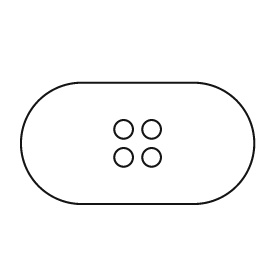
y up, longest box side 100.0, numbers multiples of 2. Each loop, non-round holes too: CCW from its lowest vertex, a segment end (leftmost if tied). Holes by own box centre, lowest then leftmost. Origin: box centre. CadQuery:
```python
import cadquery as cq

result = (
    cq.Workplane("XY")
    .moveTo(-24.0, -26.0)
    .lineTo(24.0, -26.0)
    .threePointArc((50.0, 0.0), (24.0, 26.0))
    .lineTo(-24.0, 26.0)
    .threePointArc((-50.0, 0.0), (-24.0, -26.0))
    .close()
    .moveTo(-6.0, -6.0)
    .circle(4.0)
    .moveTo(6.0, -6.0)
    .circle(4.0)
    .moveTo(-6.0, 6.0)
    .circle(4.0)
    .moveTo(6.0, 6.0)
    .circle(4.0)
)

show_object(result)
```